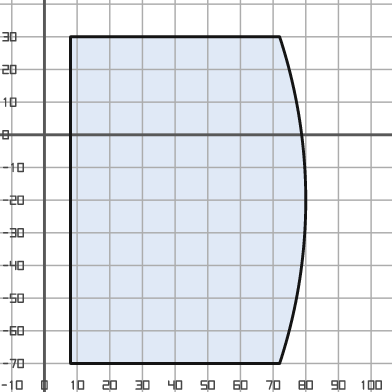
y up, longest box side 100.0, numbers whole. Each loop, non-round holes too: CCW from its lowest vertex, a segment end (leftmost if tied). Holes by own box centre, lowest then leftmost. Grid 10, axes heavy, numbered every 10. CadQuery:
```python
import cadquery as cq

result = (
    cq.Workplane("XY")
    .moveTo(8.0, -70.0)
    .lineTo(72.0, -70.0)
    .threePointArc((80.0, -20.0), (72.0, 30.0))
    .lineTo(8.0, 30.0)
    .close()
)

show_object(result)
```